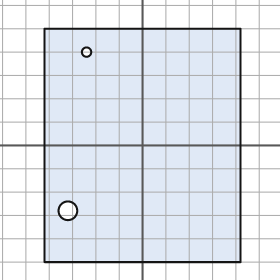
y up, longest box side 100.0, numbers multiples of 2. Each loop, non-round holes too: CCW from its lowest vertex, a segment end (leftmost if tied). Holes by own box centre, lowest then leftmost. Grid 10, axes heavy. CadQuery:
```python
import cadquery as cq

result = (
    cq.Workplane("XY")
    .moveTo(-42.0, -50.0)
    .lineTo(42.0, -50.0)
    .lineTo(42.0, 50.0)
    .lineTo(-42.0, 50.0)
    .close()
    .moveTo(-32.0, -28.0)
    .circle(4.0)
    .moveTo(-24.0, 40.0)
    .circle(2.0)
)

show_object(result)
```